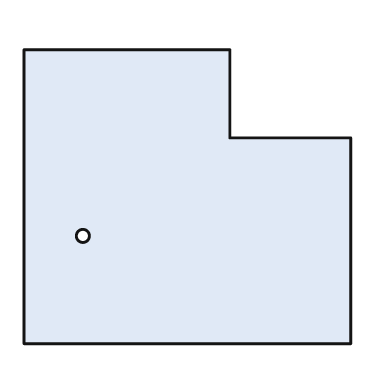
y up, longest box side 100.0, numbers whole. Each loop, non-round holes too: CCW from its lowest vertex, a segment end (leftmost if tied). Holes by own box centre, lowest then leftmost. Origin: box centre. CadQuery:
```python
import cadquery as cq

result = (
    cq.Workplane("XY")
    .moveTo(-50.0, -45.0)
    .lineTo(50.0, -45.0)
    .lineTo(50.0, 18.0)
    .lineTo(13.0, 18.0)
    .lineTo(13.0, 45.0)
    .lineTo(-50.0, 45.0)
    .close()
    .moveTo(-32.0, -12.0)
    .circle(2.0)
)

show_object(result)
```